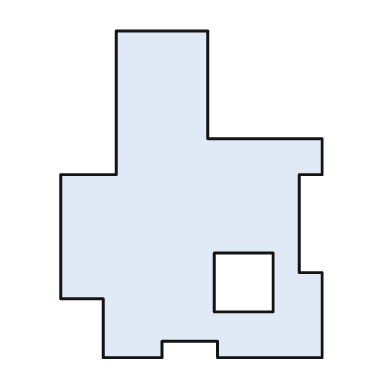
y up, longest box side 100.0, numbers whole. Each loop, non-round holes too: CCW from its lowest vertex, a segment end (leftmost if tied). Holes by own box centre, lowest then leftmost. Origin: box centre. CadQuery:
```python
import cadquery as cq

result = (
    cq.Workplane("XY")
    .moveTo(-27.0, -50.0)
    .lineTo(-9.0, -50.0)
    .lineTo(-9.0, -45.0)
    .lineTo(8.0, -45.0)
    .lineTo(8.0, -50.0)
    .lineTo(40.0, -50.0)
    .lineTo(40.0, -24.0)
    .lineTo(33.0, -24.0)
    .lineTo(33.0, 6.0)
    .lineTo(40.0, 6.0)
    .lineTo(40.0, 17.0)
    .lineTo(5.0, 17.0)
    .lineTo(5.0, 50.0)
    .lineTo(-23.0, 50.0)
    .lineTo(-23.0, 6.0)
    .lineTo(-40.0, 6.0)
    .lineTo(-40.0, -32.0)
    .lineTo(-27.0, -32.0)
    .close()
    .moveTo(7.0, -36.0)
    .lineTo(25.0, -36.0)
    .lineTo(25.0, -18.0)
    .lineTo(7.0, -18.0)
    .close()
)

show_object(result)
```